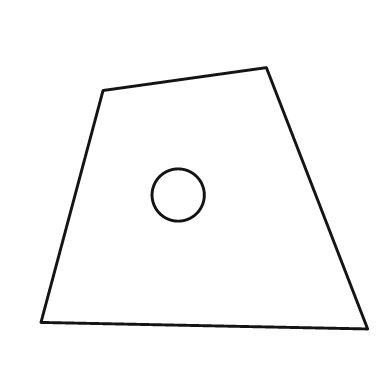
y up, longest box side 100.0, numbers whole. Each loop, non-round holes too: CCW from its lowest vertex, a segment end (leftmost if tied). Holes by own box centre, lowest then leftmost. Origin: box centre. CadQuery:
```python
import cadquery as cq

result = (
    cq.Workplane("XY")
    .moveTo(50.0, -40.0)
    .lineTo(19.0, 40.0)
    .lineTo(-31.0, 33.0)
    .lineTo(-50.0, -38.0)
    .close()
    .moveTo(-8.0, 1.0)
    .circle(8.0)
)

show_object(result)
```